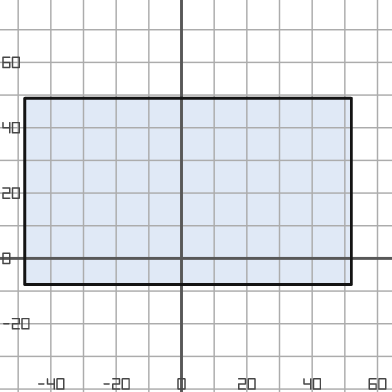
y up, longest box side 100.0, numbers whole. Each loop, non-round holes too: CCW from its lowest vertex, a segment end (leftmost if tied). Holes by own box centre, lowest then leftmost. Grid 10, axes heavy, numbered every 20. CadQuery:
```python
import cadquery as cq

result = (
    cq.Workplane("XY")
    .moveTo(-48.0, -8.0)
    .lineTo(52.0, -8.0)
    .lineTo(52.0, 49.0)
    .lineTo(-48.0, 49.0)
    .close()
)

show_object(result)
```